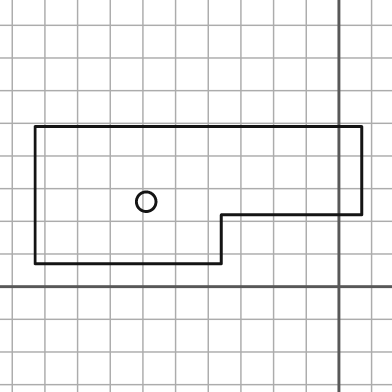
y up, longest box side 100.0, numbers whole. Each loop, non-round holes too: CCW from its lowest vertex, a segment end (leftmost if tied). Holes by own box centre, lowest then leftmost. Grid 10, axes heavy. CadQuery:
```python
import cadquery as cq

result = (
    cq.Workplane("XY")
    .moveTo(-93.0, 7.0)
    .lineTo(-36.0, 7.0)
    .lineTo(-36.0, 22.0)
    .lineTo(7.0, 22.0)
    .lineTo(7.0, 49.0)
    .lineTo(-93.0, 49.0)
    .close()
    .moveTo(-59.0, 26.0)
    .circle(3.0)
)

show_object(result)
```